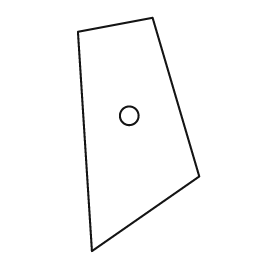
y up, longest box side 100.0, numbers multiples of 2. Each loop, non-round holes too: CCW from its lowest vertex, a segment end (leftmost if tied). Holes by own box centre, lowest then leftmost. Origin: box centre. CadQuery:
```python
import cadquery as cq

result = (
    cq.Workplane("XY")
    .moveTo(-20.0, -50.0)
    .lineTo(26.0, -18.0)
    .lineTo(6.0, 50.0)
    .lineTo(-26.0, 44.0)
    .close()
    .moveTo(-4.0, 8.0)
    .circle(4.0)
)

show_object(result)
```